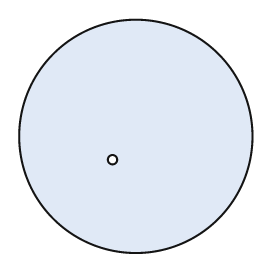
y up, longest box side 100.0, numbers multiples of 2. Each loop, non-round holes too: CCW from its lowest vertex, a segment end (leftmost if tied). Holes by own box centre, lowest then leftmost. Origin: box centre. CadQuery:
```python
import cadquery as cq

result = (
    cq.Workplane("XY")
    .moveTo(0.0, 0.0)
    .circle(50.0)
    .moveTo(-10.0, -10.0)
    .circle(2.0)
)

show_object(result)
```